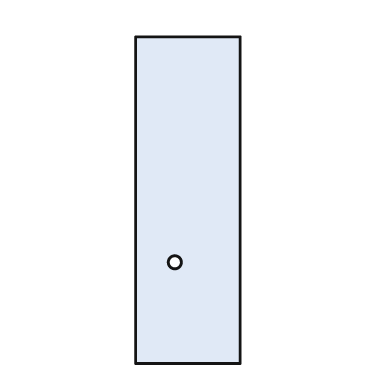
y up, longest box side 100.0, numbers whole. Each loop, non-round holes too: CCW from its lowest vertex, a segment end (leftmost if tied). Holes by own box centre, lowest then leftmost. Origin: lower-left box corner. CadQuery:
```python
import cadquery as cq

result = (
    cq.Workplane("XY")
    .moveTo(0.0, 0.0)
    .lineTo(32.0, 0.0)
    .lineTo(32.0, 100.0)
    .lineTo(0.0, 100.0)
    .close()
    .moveTo(12.0, 31.0)
    .circle(2.0)
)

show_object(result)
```